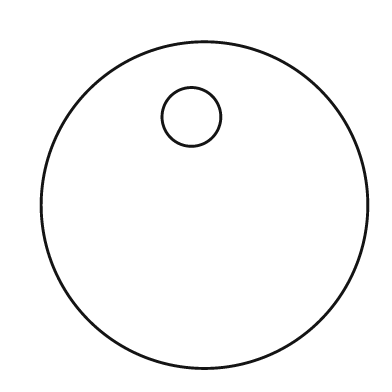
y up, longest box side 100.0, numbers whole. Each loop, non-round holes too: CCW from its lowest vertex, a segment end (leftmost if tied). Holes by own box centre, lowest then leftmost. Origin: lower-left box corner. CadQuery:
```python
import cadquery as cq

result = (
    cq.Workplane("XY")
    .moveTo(50.0, 50.0)
    .circle(50.0)
    .moveTo(46.0, 77.0)
    .circle(9.0)
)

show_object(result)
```